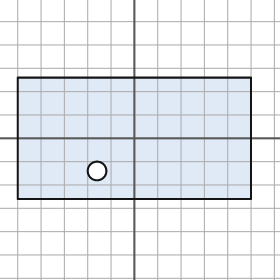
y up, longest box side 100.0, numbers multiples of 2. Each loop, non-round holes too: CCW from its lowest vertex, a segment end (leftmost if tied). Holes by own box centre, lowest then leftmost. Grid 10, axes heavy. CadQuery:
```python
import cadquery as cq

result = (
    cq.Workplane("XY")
    .moveTo(-50.0, -26.0)
    .lineTo(50.0, -26.0)
    .lineTo(50.0, 26.0)
    .lineTo(-50.0, 26.0)
    .close()
    .moveTo(-16.0, -14.0)
    .circle(4.0)
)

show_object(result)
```